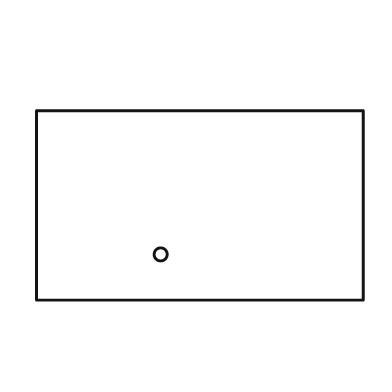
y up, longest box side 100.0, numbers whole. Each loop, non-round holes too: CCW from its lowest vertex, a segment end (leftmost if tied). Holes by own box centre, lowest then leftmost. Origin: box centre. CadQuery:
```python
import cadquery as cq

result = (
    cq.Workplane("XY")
    .moveTo(-50.0, -29.0)
    .lineTo(50.0, -29.0)
    .lineTo(50.0, 29.0)
    .lineTo(-50.0, 29.0)
    .close()
    .moveTo(-12.0, -15.0)
    .circle(2.0)
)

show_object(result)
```